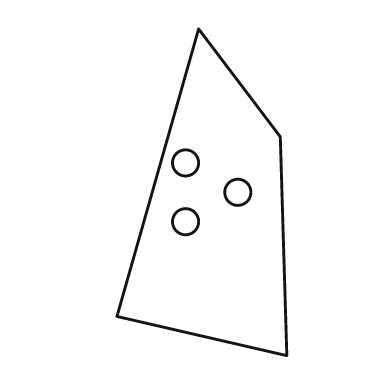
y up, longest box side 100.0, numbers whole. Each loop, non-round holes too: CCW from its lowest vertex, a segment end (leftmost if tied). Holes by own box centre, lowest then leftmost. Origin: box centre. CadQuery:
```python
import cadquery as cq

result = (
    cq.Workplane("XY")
    .moveTo(26.0, -50.0)
    .lineTo(24.0, 17.0)
    .lineTo(-1.0, 50.0)
    .lineTo(-26.0, -38.0)
    .close()
    .moveTo(-5.0, -9.0)
    .circle(4.0)
    .moveTo(11.0, 0.0)
    .circle(4.0)
    .moveTo(-5.0, 9.0)
    .circle(4.0)
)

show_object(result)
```